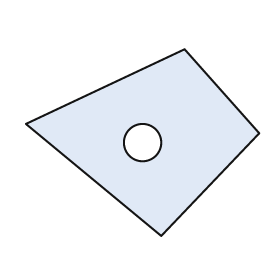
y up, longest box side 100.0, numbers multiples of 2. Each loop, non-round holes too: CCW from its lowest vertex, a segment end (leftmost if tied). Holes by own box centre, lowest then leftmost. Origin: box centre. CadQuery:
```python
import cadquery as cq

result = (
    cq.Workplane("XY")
    .moveTo(8.0, -40.0)
    .lineTo(50.0, 4.0)
    .lineTo(18.0, 40.0)
    .lineTo(-50.0, 8.0)
    .close()
    .moveTo(0.0, 0.0)
    .circle(8.0)
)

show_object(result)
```